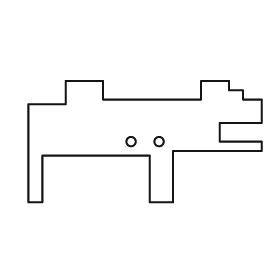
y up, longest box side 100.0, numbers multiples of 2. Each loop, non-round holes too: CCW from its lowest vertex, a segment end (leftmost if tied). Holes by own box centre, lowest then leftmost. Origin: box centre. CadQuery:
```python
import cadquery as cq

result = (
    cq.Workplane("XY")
    .moveTo(-50.0, -26.0)
    .lineTo(-44.0, -26.0)
    .lineTo(-44.0, -6.0)
    .lineTo(2.0, -6.0)
    .lineTo(2.0, -26.0)
    .lineTo(12.0, -26.0)
    .lineTo(12.0, -4.0)
    .lineTo(50.0, -4.0)
    .lineTo(50.0, 0.0)
    .lineTo(32.0, 0.0)
    .lineTo(32.0, 8.0)
    .lineTo(50.0, 8.0)
    .lineTo(50.0, 18.0)
    .lineTo(42.0, 18.0)
    .lineTo(42.0, 22.0)
    .lineTo(36.0, 22.0)
    .lineTo(36.0, 26.0)
    .lineTo(24.0, 26.0)
    .lineTo(24.0, 18.0)
    .lineTo(-18.0, 18.0)
    .lineTo(-18.0, 26.0)
    .lineTo(-34.0, 26.0)
    .lineTo(-34.0, 16.0)
    .lineTo(-50.0, 16.0)
    .close()
    .moveTo(-6.0, 0.0)
    .circle(2.0)
    .moveTo(6.0, 0.0)
    .circle(2.0)
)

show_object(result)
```